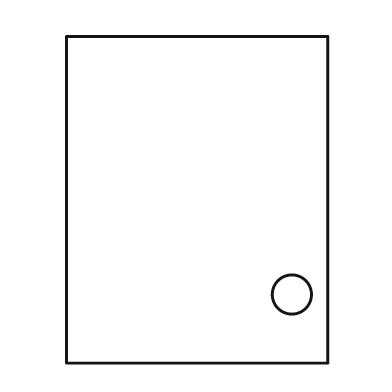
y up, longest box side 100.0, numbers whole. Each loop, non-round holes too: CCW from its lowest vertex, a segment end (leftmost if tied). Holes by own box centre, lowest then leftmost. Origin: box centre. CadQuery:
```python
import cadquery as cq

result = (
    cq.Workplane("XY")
    .moveTo(-40.0, -50.0)
    .lineTo(40.0, -50.0)
    .lineTo(40.0, 50.0)
    .lineTo(-40.0, 50.0)
    .close()
    .moveTo(29.0, -29.0)
    .circle(6.0)
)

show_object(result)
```